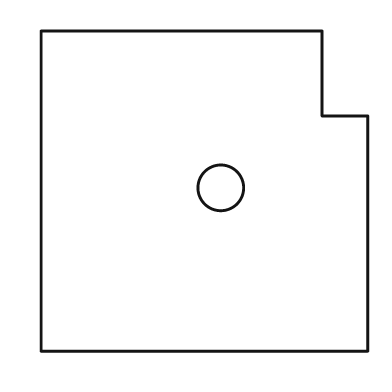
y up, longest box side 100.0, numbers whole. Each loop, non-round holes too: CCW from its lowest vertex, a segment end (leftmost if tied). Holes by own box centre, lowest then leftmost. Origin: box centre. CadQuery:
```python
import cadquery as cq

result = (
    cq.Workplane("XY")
    .moveTo(-50.0, -49.0)
    .lineTo(50.0, -49.0)
    .lineTo(50.0, 23.0)
    .lineTo(36.0, 23.0)
    .lineTo(36.0, 49.0)
    .lineTo(-50.0, 49.0)
    .close()
    .moveTo(5.0, 1.0)
    .circle(7.0)
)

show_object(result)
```